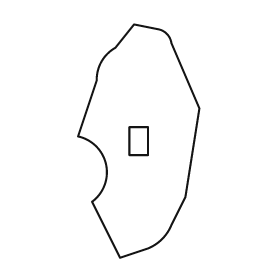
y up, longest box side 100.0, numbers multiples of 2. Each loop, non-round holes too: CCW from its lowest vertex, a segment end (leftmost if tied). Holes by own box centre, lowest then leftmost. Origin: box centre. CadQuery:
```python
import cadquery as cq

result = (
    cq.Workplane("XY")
    .moveTo(-8.0, -50.0)
    .lineTo(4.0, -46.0)
    .threePointArc((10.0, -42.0), (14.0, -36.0))
    .lineTo(20.0, -24.0)
    .lineTo(26.0, 14.0)
    .lineTo(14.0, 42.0)
    .threePointArc((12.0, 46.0), (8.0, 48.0))
    .lineTo(-2.0, 50.0)
    .lineTo(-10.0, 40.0)
    .threePointArc((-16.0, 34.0), (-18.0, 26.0))
    .lineTo(-26.0, 2.0)
    .threePointArc((-14.0, -10.0), (-20.0, -26.0))
    .close()
    .moveTo(-4.0, -6.0)
    .lineTo(4.0, -6.0)
    .lineTo(4.0, 6.0)
    .lineTo(-4.0, 6.0)
    .close()
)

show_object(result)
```